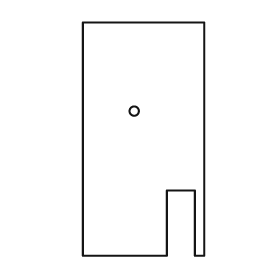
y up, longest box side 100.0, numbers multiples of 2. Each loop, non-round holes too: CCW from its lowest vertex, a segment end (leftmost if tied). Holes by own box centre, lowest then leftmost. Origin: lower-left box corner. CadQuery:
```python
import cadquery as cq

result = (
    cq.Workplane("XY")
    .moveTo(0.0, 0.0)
    .lineTo(36.0, 0.0)
    .lineTo(36.0, 28.0)
    .lineTo(48.0, 28.0)
    .lineTo(48.0, 0.0)
    .lineTo(52.0, 0.0)
    .lineTo(52.0, 100.0)
    .lineTo(0.0, 100.0)
    .close()
    .moveTo(22.0, 62.0)
    .circle(2.0)
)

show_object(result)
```